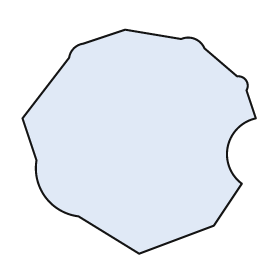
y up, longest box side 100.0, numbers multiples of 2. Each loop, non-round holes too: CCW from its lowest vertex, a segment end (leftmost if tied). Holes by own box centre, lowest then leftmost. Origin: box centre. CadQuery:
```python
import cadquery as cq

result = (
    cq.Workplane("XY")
    .moveTo(0.0, -48.0)
    .lineTo(32.0, -36.0)
    .lineTo(44.0, -18.0)
    .threePointArc((38.0, -2.0), (50.0, 10.0))
    .lineTo(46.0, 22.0)
    .threePointArc((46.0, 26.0), (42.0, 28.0))
    .lineTo(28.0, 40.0)
    .threePointArc((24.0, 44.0), (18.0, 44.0))
    .lineTo(-6.0, 48.0)
    .lineTo(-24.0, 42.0)
    .threePointArc((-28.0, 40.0), (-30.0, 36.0))
    .lineTo(-50.0, 10.0)
    .lineTo(-44.0, -8.0)
    .threePointArc((-40.0, -24.0), (-26.0, -32.0))
    .close()
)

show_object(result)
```